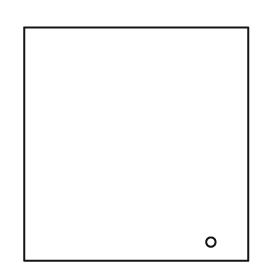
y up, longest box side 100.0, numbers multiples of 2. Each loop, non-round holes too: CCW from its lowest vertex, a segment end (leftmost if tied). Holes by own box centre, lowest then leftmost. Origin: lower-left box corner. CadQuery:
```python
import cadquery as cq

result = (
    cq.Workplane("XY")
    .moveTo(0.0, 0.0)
    .lineTo(96.0, 0.0)
    .lineTo(96.0, 100.0)
    .lineTo(0.0, 100.0)
    .close()
    .moveTo(80.0, 8.0)
    .circle(2.0)
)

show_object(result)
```